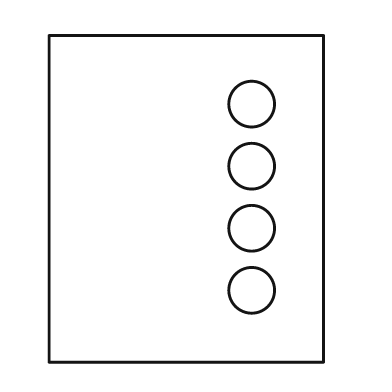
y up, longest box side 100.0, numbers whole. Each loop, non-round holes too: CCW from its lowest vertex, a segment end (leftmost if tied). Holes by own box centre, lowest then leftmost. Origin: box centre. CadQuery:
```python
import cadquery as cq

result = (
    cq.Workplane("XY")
    .moveTo(-42.0, -50.0)
    .lineTo(42.0, -50.0)
    .lineTo(42.0, 50.0)
    .lineTo(-42.0, 50.0)
    .close()
    .moveTo(20.0, -28.0)
    .circle(7.0)
    .moveTo(20.0, -9.0)
    .circle(7.0)
    .moveTo(20.0, 10.0)
    .circle(7.0)
    .moveTo(20.0, 29.0)
    .circle(7.0)
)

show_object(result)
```